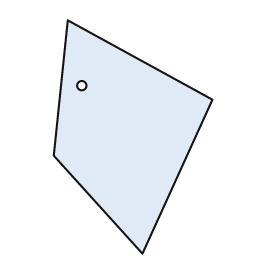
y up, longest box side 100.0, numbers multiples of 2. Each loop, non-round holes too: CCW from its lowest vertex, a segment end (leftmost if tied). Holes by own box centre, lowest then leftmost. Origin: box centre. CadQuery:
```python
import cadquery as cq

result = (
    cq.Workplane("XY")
    .moveTo(4.0, -50.0)
    .lineTo(34.0, 16.0)
    .lineTo(-28.0, 50.0)
    .lineTo(-34.0, -8.0)
    .close()
    .moveTo(-22.0, 22.0)
    .circle(2.0)
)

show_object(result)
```